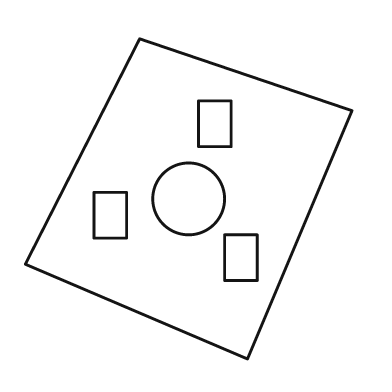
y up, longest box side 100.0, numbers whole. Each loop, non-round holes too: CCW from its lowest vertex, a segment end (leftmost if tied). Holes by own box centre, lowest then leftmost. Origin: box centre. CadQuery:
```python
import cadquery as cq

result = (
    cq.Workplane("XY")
    .moveTo(18.0, -49.0)
    .lineTo(50.0, 27.0)
    .lineTo(-15.0, 49.0)
    .lineTo(-50.0, -20.0)
    .close()
    .moveTo(11.0, -25.0)
    .lineTo(21.0, -25.0)
    .lineTo(21.0, -11.0)
    .lineTo(11.0, -11.0)
    .close()
    .moveTo(-29.0, -12.0)
    .lineTo(-19.0, -12.0)
    .lineTo(-19.0, 2.0)
    .lineTo(-29.0, 2.0)
    .close()
    .moveTo(0.0, 0.0)
    .circle(11.0)
    .moveTo(3.0, 16.0)
    .lineTo(13.0, 16.0)
    .lineTo(13.0, 30.0)
    .lineTo(3.0, 30.0)
    .close()
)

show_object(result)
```